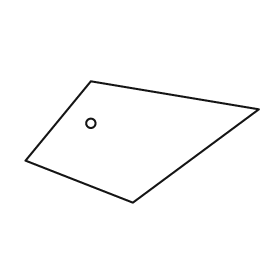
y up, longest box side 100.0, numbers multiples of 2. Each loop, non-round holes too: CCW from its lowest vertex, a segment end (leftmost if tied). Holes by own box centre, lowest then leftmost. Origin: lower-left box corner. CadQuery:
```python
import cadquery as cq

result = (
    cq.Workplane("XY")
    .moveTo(46.0, 0.0)
    .lineTo(100.0, 40.0)
    .lineTo(28.0, 52.0)
    .lineTo(0.0, 18.0)
    .close()
    .moveTo(28.0, 34.0)
    .circle(2.0)
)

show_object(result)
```